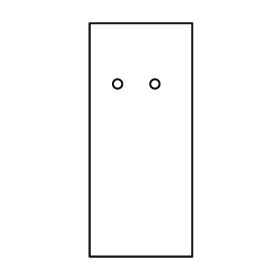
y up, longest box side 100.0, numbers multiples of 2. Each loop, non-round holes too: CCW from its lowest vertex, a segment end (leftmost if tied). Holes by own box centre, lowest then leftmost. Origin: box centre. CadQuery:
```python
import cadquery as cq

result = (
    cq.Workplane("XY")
    .moveTo(-22.0, -50.0)
    .lineTo(22.0, -50.0)
    .lineTo(22.0, 50.0)
    .lineTo(-22.0, 50.0)
    .close()
    .moveTo(-10.0, 24.0)
    .circle(2.0)
    .moveTo(6.0, 24.0)
    .circle(2.0)
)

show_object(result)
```